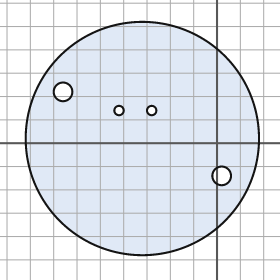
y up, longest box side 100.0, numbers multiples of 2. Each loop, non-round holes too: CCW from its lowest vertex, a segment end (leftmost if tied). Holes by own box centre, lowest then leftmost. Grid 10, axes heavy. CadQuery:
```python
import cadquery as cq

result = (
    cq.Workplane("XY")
    .moveTo(-32.0, 2.0)
    .circle(50.0)
    .moveTo(2.0, -14.0)
    .circle(4.0)
    .moveTo(-42.0, 14.0)
    .circle(2.0)
    .moveTo(-28.0, 14.0)
    .circle(2.0)
    .moveTo(-66.0, 22.0)
    .circle(4.0)
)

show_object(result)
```